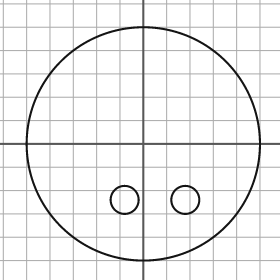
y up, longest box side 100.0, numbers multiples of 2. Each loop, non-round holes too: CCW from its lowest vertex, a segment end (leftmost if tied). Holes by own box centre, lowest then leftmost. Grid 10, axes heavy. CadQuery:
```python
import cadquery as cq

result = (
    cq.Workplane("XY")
    .moveTo(0.0, 0.0)
    .circle(50.0)
    .moveTo(-8.0, -24.0)
    .circle(6.0)
    .moveTo(18.0, -24.0)
    .circle(6.0)
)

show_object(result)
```